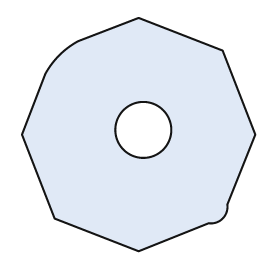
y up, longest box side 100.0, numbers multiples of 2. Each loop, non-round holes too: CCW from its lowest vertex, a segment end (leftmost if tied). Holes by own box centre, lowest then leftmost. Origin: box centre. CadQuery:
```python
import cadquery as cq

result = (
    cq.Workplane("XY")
    .moveTo(0.0, -50.0)
    .lineTo(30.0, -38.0)
    .threePointArc((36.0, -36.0), (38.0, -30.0))
    .lineTo(50.0, 0.0)
    .lineTo(36.0, 36.0)
    .lineTo(0.0, 50.0)
    .lineTo(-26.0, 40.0)
    .threePointArc((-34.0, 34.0), (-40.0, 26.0))
    .lineTo(-50.0, 0.0)
    .lineTo(-36.0, -36.0)
    .close()
    .moveTo(2.0, 2.0)
    .circle(12.0)
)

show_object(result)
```